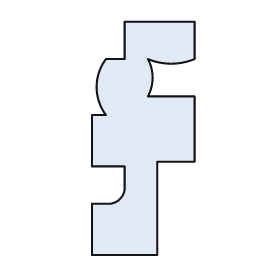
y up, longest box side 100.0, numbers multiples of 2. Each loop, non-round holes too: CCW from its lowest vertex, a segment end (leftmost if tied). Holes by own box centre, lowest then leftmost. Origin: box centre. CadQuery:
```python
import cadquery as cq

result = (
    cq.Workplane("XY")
    .moveTo(-22.0, -50.0)
    .lineTo(6.0, -50.0)
    .lineTo(6.0, -10.0)
    .lineTo(22.0, -10.0)
    .lineTo(22.0, 18.0)
    .lineTo(2.0, 18.0)
    .threePointArc((4.0, 26.0), (2.0, 34.0))
    .threePointArc((12.0, 32.0), (22.0, 34.0))
    .lineTo(22.0, 50.0)
    .lineTo(-8.0, 50.0)
    .lineTo(-8.0, 34.0)
    .lineTo(-16.0, 34.0)
    .threePointArc((-20.0, 22.0), (-16.0, 10.0))
    .lineTo(-22.0, 10.0)
    .lineTo(-22.0, -12.0)
    .lineTo(-8.0, -12.0)
    .lineTo(-8.0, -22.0)
    .threePointArc((-10.0, -26.0), (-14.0, -28.0))
    .lineTo(-22.0, -28.0)
    .close()
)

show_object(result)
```